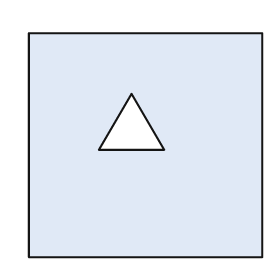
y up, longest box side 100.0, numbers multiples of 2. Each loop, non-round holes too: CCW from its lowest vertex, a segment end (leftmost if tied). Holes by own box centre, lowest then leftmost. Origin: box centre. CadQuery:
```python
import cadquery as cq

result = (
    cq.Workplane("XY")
    .moveTo(-50.0, -48.0)
    .lineTo(50.0, -48.0)
    .lineTo(50.0, 48.0)
    .lineTo(-50.0, 48.0)
    .close()
    .moveTo(-20.0, -2.0)
    .lineTo(8.0, -2.0)
    .lineTo(-6.0, 22.0)
    .close()
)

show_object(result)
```